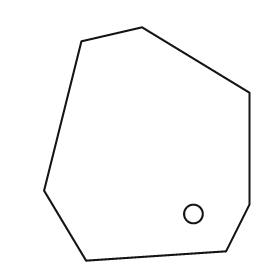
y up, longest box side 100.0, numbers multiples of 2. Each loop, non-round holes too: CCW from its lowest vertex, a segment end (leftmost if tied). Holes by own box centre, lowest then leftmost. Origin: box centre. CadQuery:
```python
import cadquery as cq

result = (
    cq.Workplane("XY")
    .moveTo(-26.0, -50.0)
    .lineTo(34.0, -46.0)
    .lineTo(44.0, -26.0)
    .lineTo(44.0, 22.0)
    .lineTo(-2.0, 50.0)
    .lineTo(-28.0, 44.0)
    .lineTo(-44.0, -20.0)
    .close()
    .moveTo(20.0, -30.0)
    .circle(4.0)
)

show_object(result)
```